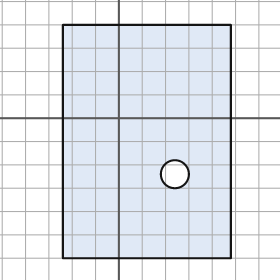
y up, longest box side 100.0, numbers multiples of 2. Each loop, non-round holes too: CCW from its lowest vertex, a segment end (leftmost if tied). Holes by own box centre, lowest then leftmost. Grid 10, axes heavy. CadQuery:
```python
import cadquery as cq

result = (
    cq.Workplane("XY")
    .moveTo(-24.0, -60.0)
    .lineTo(48.0, -60.0)
    .lineTo(48.0, 40.0)
    .lineTo(-24.0, 40.0)
    .close()
    .moveTo(24.0, -24.0)
    .circle(6.0)
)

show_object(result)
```